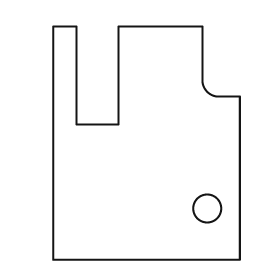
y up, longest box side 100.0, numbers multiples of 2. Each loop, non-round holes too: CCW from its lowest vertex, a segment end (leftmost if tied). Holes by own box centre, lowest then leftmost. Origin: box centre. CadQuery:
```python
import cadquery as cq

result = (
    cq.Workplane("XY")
    .moveTo(-40.0, -50.0)
    .lineTo(40.0, -50.0)
    .lineTo(40.0, 20.0)
    .lineTo(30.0, 20.0)
    .threePointArc((26.0, 22.0), (24.0, 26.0))
    .lineTo(24.0, 50.0)
    .lineTo(-12.0, 50.0)
    .lineTo(-12.0, 8.0)
    .lineTo(-30.0, 8.0)
    .lineTo(-30.0, 50.0)
    .lineTo(-40.0, 50.0)
    .close()
    .moveTo(26.0, -28.0)
    .circle(6.0)
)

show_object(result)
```